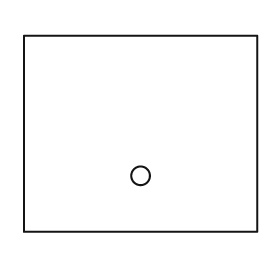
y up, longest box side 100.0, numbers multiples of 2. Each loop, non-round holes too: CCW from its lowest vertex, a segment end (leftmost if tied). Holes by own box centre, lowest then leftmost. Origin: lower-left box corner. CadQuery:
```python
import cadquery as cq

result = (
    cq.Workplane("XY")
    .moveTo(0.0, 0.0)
    .lineTo(100.0, 0.0)
    .lineTo(100.0, 84.0)
    .lineTo(0.0, 84.0)
    .close()
    .moveTo(50.0, 24.0)
    .circle(4.0)
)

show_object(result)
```